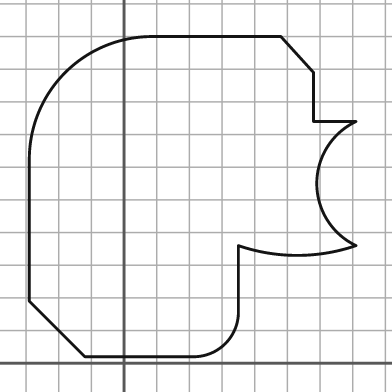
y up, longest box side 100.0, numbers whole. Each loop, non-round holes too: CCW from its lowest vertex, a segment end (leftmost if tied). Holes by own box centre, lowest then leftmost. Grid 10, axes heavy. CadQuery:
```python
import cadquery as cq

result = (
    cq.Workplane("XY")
    .moveTo(-12.0, 2.0)
    .lineTo(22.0, 2.0)
    .threePointArc((31.0, 6.0), (35.0, 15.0))
    .lineTo(35.0, 36.0)
    .threePointArc((53.0, 33.0), (71.0, 36.0))
    .threePointArc((59.0, 55.0), (71.0, 74.0))
    .lineTo(58.0, 74.0)
    .lineTo(58.0, 89.0)
    .lineTo(48.0, 100.0)
    .lineTo(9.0, 100.0)
    .threePointArc((-18.0, 89.0), (-29.0, 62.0))
    .lineTo(-29.0, 19.0)
    .close()
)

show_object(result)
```